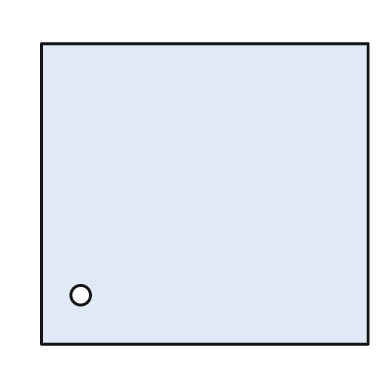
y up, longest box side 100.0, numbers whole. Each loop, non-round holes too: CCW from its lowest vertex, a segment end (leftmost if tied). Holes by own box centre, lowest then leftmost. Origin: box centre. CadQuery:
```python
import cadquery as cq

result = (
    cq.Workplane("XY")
    .moveTo(-50.0, -46.0)
    .lineTo(50.0, -46.0)
    .lineTo(50.0, 46.0)
    .lineTo(-50.0, 46.0)
    .close()
    .moveTo(-38.0, -31.0)
    .circle(3.0)
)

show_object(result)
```